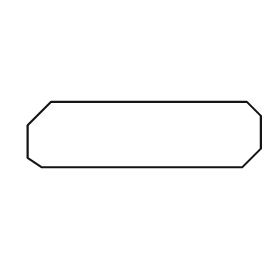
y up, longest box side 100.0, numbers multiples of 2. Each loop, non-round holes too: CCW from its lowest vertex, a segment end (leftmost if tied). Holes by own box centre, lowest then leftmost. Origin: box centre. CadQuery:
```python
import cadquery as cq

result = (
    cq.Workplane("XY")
    .moveTo(-44.0, -14.0)
    .lineTo(42.0, -14.0)
    .lineTo(50.0, -6.0)
    .lineTo(50.0, 8.0)
    .lineTo(44.0, 14.0)
    .lineTo(-40.0, 14.0)
    .lineTo(-50.0, 4.0)
    .lineTo(-50.0, -10.0)
    .close()
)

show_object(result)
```